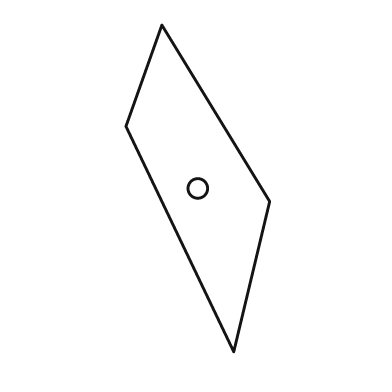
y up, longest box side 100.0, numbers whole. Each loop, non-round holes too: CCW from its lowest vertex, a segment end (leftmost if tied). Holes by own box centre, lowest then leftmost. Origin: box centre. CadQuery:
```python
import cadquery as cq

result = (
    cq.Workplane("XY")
    .moveTo(11.0, -50.0)
    .lineTo(22.0, -4.0)
    .lineTo(-11.0, 50.0)
    .lineTo(-22.0, 19.0)
    .close()
    .moveTo(0.0, 0.0)
    .circle(3.0)
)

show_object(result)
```